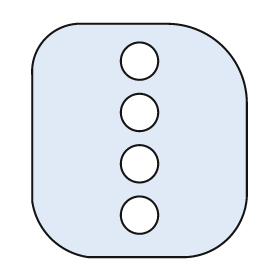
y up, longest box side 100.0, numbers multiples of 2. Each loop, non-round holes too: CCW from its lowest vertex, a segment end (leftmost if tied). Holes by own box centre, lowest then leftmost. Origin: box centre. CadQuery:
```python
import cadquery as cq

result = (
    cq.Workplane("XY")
    .moveTo(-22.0, -50.0)
    .lineTo(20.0, -50.0)
    .threePointArc((38.0, -42.0), (46.0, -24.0))
    .lineTo(46.0, 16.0)
    .threePointArc((36.0, 40.0), (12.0, 50.0))
    .lineTo(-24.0, 50.0)
    .threePointArc((-40.0, 44.0), (-46.0, 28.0))
    .lineTo(-46.0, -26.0)
    .threePointArc((-38.0, -42.0), (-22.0, -50.0))
    .close()
    .moveTo(0.0, -32.0)
    .circle(8.0)
    .moveTo(0.0, -10.0)
    .circle(8.0)
    .moveTo(0.0, 12.0)
    .circle(8.0)
    .moveTo(0.0, 34.0)
    .circle(8.0)
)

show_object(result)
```